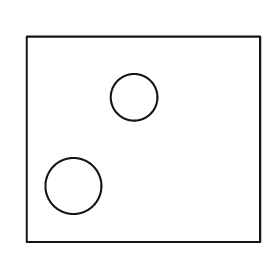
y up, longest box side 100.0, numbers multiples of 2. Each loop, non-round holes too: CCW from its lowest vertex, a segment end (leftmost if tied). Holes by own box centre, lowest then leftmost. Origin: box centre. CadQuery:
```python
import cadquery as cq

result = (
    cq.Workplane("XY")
    .moveTo(-50.0, -44.0)
    .lineTo(50.0, -44.0)
    .lineTo(50.0, 44.0)
    .lineTo(-50.0, 44.0)
    .close()
    .moveTo(-30.0, -20.0)
    .circle(12.0)
    .moveTo(-4.0, 18.0)
    .circle(10.0)
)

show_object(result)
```